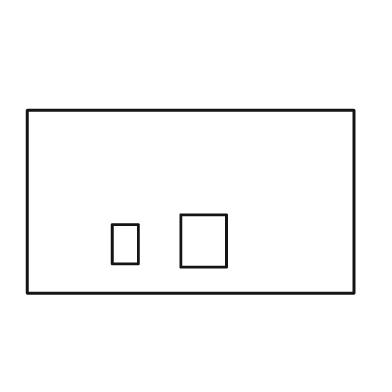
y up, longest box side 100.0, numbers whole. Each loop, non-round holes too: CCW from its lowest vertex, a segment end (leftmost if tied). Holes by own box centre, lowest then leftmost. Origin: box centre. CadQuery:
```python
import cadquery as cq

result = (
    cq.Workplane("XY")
    .moveTo(-50.0, -28.0)
    .lineTo(50.0, -28.0)
    .lineTo(50.0, 28.0)
    .lineTo(-50.0, 28.0)
    .close()
    .moveTo(-24.0, -19.0)
    .lineTo(-16.0, -19.0)
    .lineTo(-16.0, -7.0)
    .lineTo(-24.0, -7.0)
    .close()
    .moveTo(-3.0, -20.0)
    .lineTo(11.0, -20.0)
    .lineTo(11.0, -4.0)
    .lineTo(-3.0, -4.0)
    .close()
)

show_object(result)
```